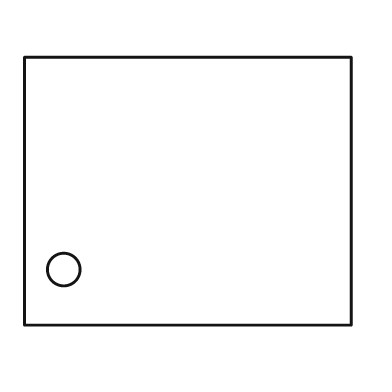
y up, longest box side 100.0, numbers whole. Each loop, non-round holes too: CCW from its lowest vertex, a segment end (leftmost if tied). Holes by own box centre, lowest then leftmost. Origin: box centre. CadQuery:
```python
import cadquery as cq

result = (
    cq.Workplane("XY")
    .moveTo(-50.0, -41.0)
    .lineTo(50.0, -41.0)
    .lineTo(50.0, 41.0)
    .lineTo(-50.0, 41.0)
    .close()
    .moveTo(-38.0, -24.0)
    .circle(5.0)
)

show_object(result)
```